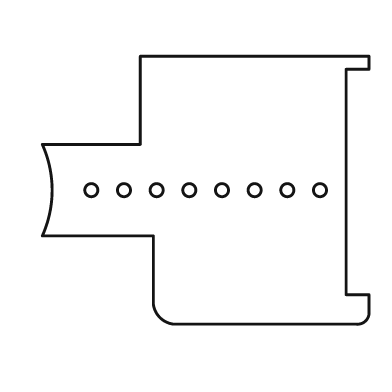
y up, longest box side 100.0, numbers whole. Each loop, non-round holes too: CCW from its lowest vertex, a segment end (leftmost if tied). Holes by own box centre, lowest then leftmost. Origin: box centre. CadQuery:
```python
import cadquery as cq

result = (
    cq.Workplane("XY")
    .moveTo(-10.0, -41.0)
    .lineTo(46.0, -41.0)
    .threePointArc((49.0, -40.0), (50.0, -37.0))
    .lineTo(50.0, -32.0)
    .lineTo(43.0, -32.0)
    .lineTo(43.0, 37.0)
    .lineTo(50.0, 37.0)
    .lineTo(50.0, 41.0)
    .lineTo(-20.0, 41.0)
    .lineTo(-20.0, 14.0)
    .lineTo(-50.0, 14.0)
    .threePointArc((-47.0, 0.0), (-50.0, -14.0))
    .lineTo(-16.0, -14.0)
    .lineTo(-16.0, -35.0)
    .threePointArc((-14.0, -39.0), (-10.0, -41.0))
    .close()
    .moveTo(-35.0, 0.0)
    .circle(2.0)
    .moveTo(-25.0, 0.0)
    .circle(2.0)
    .moveTo(-15.0, 0.0)
    .circle(2.0)
    .moveTo(-5.0, 0.0)
    .circle(2.0)
    .moveTo(5.0, 0.0)
    .circle(2.0)
    .moveTo(15.0, 0.0)
    .circle(2.0)
    .moveTo(25.0, 0.0)
    .circle(2.0)
    .moveTo(35.0, 0.0)
    .circle(2.0)
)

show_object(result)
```